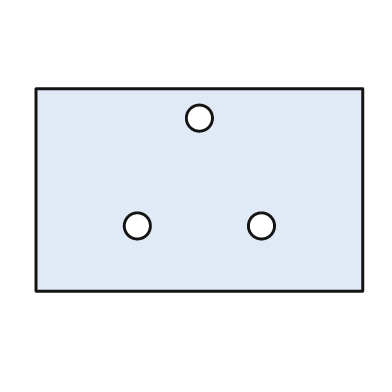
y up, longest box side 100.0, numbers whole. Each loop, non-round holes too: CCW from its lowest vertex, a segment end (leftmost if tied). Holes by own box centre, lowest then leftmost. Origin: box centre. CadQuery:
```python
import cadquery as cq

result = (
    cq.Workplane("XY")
    .moveTo(-50.0, -31.0)
    .lineTo(50.0, -31.0)
    .lineTo(50.0, 31.0)
    .lineTo(-50.0, 31.0)
    .close()
    .moveTo(-19.0, -11.0)
    .circle(4.0)
    .moveTo(19.0, -11.0)
    .circle(4.0)
    .moveTo(0.0, 22.0)
    .circle(4.0)
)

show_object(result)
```